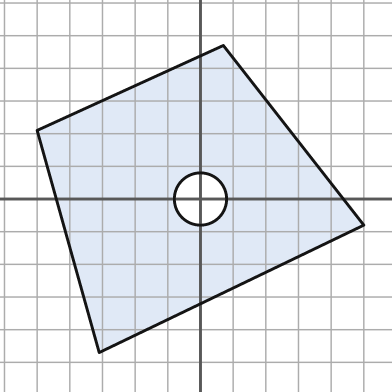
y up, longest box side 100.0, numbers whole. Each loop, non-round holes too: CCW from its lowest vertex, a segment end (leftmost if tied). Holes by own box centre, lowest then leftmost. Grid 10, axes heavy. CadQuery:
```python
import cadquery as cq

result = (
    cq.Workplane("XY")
    .moveTo(-31.0, -47.0)
    .lineTo(50.0, -8.0)
    .lineTo(7.0, 47.0)
    .lineTo(-50.0, 21.0)
    .close()
    .moveTo(0.0, 0.0)
    .circle(8.0)
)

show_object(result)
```